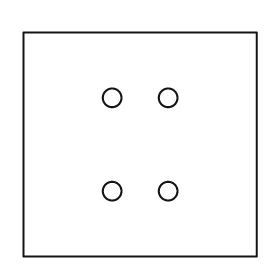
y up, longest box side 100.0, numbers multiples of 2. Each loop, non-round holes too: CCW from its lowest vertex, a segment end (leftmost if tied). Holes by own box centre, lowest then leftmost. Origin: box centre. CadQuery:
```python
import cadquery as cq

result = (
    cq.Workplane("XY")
    .moveTo(-50.0, -48.0)
    .lineTo(50.0, -48.0)
    .lineTo(50.0, 48.0)
    .lineTo(-50.0, 48.0)
    .close()
    .moveTo(-12.0, -20.0)
    .circle(4.0)
    .moveTo(12.0, -20.0)
    .circle(4.0)
    .moveTo(-12.0, 20.0)
    .circle(4.0)
    .moveTo(12.0, 20.0)
    .circle(4.0)
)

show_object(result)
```